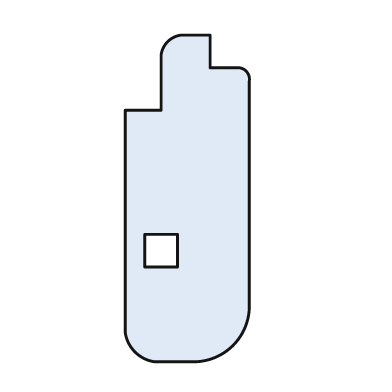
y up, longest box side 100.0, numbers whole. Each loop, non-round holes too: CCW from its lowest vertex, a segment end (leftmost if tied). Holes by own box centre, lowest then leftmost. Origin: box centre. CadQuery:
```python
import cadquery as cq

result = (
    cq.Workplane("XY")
    .moveTo(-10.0, -50.0)
    .lineTo(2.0, -50.0)
    .threePointArc((14.0, -45.0), (19.0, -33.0))
    .lineTo(19.0, 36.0)
    .threePointArc((18.0, 39.0), (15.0, 40.0))
    .lineTo(7.0, 40.0)
    .lineTo(7.0, 50.0)
    .lineTo(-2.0, 50.0)
    .threePointArc((-6.0, 48.0), (-8.0, 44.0))
    .lineTo(-8.0, 27.0)
    .lineTo(-19.0, 27.0)
    .lineTo(-19.0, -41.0)
    .threePointArc((-16.0, -47.0), (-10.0, -50.0))
    .close()
    .moveTo(-13.0, -21.0)
    .lineTo(-3.0, -21.0)
    .lineTo(-3.0, -11.0)
    .lineTo(-13.0, -11.0)
    .close()
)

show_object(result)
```